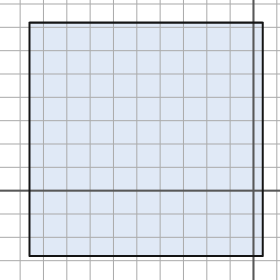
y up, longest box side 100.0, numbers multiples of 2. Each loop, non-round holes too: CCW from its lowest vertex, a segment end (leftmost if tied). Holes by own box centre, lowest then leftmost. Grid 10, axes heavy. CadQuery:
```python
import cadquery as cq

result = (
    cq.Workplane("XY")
    .moveTo(-96.0, -28.0)
    .lineTo(4.0, -28.0)
    .lineTo(4.0, 72.0)
    .lineTo(-96.0, 72.0)
    .close()
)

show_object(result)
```